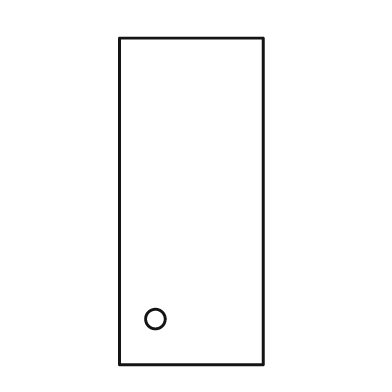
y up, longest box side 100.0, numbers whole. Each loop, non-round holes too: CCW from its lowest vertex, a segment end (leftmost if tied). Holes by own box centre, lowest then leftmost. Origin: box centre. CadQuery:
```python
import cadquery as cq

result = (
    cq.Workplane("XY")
    .moveTo(-22.0, -50.0)
    .lineTo(22.0, -50.0)
    .lineTo(22.0, 50.0)
    .lineTo(-22.0, 50.0)
    .close()
    .moveTo(-11.0, -36.0)
    .circle(3.0)
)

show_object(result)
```